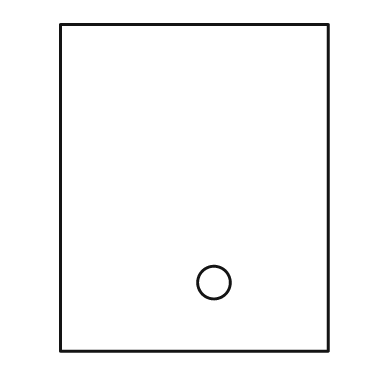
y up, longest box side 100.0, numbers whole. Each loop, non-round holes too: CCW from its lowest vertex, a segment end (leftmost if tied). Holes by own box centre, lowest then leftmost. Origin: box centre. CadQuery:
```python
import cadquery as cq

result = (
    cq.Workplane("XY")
    .moveTo(-41.0, -50.0)
    .lineTo(41.0, -50.0)
    .lineTo(41.0, 50.0)
    .lineTo(-41.0, 50.0)
    .close()
    .moveTo(6.0, -29.0)
    .circle(5.0)
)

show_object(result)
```